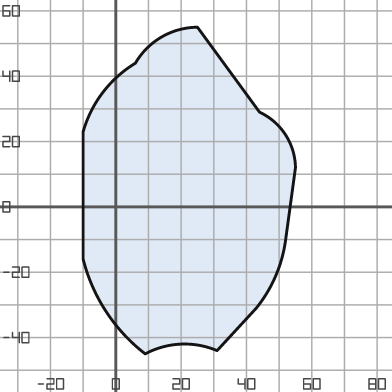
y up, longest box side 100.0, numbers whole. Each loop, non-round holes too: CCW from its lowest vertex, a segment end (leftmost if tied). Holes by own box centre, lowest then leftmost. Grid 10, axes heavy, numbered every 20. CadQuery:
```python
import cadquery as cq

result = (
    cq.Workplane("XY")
    .moveTo(9.0, -45.0)
    .threePointArc((20.0, -42.0), (31.0, -44.0))
    .lineTo(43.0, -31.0)
    .threePointArc((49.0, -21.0), (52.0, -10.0))
    .lineTo(55.0, 12.0)
    .threePointArc((52.0, 22.0), (44.0, 29.0))
    .lineTo(25.0, 55.0)
    .threePointArc((14.0, 52.0), (6.0, 44.0))
    .threePointArc((-4.0, 35.0), (-10.0, 23.0))
    .lineTo(-10.0, -16.0)
    .threePointArc((-3.0, -32.0), (9.0, -45.0))
    .close()
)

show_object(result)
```